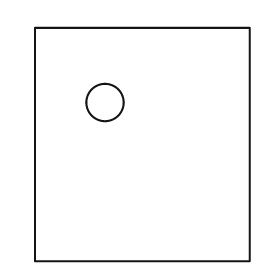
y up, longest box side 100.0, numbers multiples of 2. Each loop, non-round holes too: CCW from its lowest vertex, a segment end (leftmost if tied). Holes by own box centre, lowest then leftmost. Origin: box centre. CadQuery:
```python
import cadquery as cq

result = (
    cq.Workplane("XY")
    .moveTo(-46.0, -50.0)
    .lineTo(46.0, -50.0)
    .lineTo(46.0, 50.0)
    .lineTo(-46.0, 50.0)
    .close()
    .moveTo(-16.0, 18.0)
    .circle(8.0)
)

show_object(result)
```